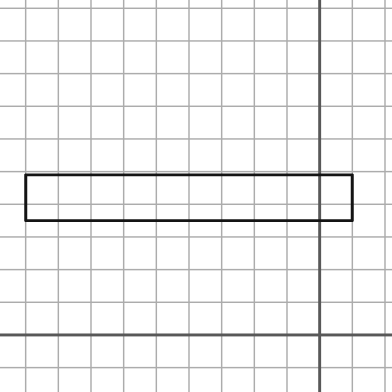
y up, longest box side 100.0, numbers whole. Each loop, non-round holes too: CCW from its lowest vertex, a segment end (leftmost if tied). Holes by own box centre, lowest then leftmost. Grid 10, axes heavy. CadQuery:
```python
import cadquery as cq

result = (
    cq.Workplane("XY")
    .moveTo(-90.0, 35.0)
    .lineTo(10.0, 35.0)
    .lineTo(10.0, 49.0)
    .lineTo(-90.0, 49.0)
    .close()
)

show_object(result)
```